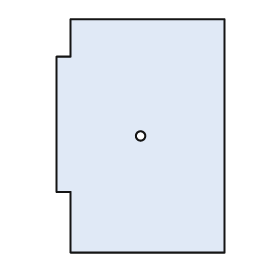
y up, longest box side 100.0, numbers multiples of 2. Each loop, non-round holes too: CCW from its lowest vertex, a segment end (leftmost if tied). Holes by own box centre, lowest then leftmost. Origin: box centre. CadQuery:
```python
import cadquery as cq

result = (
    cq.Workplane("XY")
    .moveTo(-30.0, -50.0)
    .lineTo(36.0, -50.0)
    .lineTo(36.0, 50.0)
    .lineTo(-30.0, 50.0)
    .lineTo(-30.0, 34.0)
    .lineTo(-36.0, 34.0)
    .lineTo(-36.0, -24.0)
    .lineTo(-30.0, -24.0)
    .close()
    .moveTo(0.0, 0.0)
    .circle(2.0)
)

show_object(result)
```